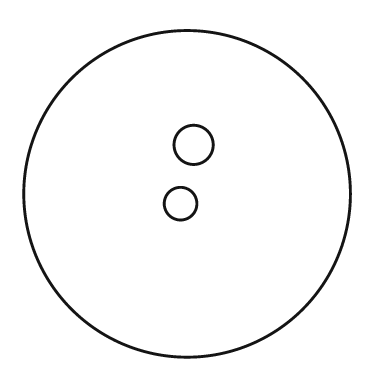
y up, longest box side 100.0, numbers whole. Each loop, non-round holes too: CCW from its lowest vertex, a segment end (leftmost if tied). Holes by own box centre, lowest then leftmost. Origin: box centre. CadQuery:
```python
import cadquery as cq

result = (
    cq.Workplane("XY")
    .moveTo(0.0, 0.0)
    .circle(50.0)
    .moveTo(-2.0, -3.0)
    .circle(5.0)
    .moveTo(2.0, 15.0)
    .circle(6.0)
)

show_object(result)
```